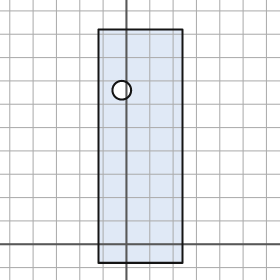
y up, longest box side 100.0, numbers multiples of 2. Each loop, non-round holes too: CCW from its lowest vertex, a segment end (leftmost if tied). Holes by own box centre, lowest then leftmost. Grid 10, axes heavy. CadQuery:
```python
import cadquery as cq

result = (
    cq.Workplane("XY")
    .moveTo(-12.0, -8.0)
    .lineTo(24.0, -8.0)
    .lineTo(24.0, 92.0)
    .lineTo(-12.0, 92.0)
    .close()
    .moveTo(-2.0, 66.0)
    .circle(4.0)
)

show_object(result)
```